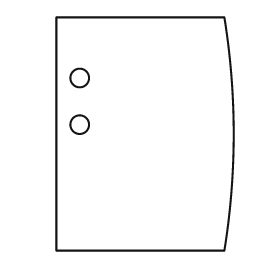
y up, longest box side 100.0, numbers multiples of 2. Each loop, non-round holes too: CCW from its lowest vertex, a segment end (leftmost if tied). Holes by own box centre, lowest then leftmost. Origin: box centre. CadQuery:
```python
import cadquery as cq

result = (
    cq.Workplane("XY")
    .moveTo(-38.0, -50.0)
    .lineTo(34.0, -50.0)
    .threePointArc((38.0, 0.0), (34.0, 50.0))
    .lineTo(-38.0, 50.0)
    .close()
    .moveTo(-28.0, 4.0)
    .circle(4.0)
    .moveTo(-28.0, 24.0)
    .circle(4.0)
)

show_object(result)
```